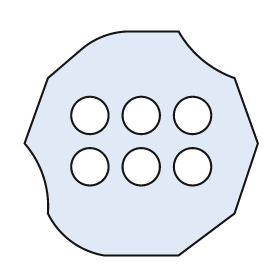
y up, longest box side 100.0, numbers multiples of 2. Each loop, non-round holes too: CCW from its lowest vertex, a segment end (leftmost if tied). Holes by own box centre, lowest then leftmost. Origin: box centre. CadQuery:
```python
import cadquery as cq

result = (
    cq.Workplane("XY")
    .moveTo(-16.0, -48.0)
    .lineTo(16.0, -48.0)
    .lineTo(40.0, -30.0)
    .lineTo(50.0, 0.0)
    .lineTo(40.0, 28.0)
    .threePointArc((26.0, 36.0), (16.0, 48.0))
    .lineTo(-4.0, 48.0)
    .threePointArc((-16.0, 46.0), (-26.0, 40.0))
    .lineTo(-40.0, 28.0)
    .lineTo(-50.0, 0.0)
    .threePointArc((-42.0, -14.0), (-40.0, -30.0))
    .threePointArc((-30.0, -42.0), (-16.0, -48.0))
    .close()
    .moveTo(-22.0, -10.0)
    .circle(8.0)
    .moveTo(0.0, -10.0)
    .circle(8.0)
    .moveTo(22.0, -10.0)
    .circle(8.0)
    .moveTo(-22.0, 12.0)
    .circle(8.0)
    .moveTo(0.0, 12.0)
    .circle(8.0)
    .moveTo(22.0, 12.0)
    .circle(8.0)
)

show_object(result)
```